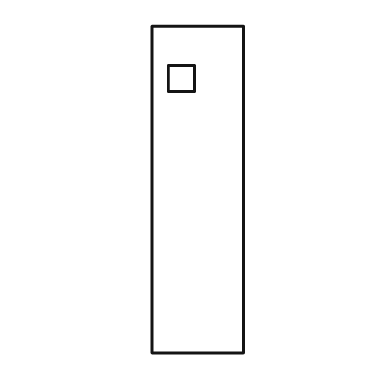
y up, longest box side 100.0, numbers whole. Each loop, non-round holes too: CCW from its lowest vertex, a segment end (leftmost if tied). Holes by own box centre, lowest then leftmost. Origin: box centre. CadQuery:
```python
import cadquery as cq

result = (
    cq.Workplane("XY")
    .moveTo(-14.0, -50.0)
    .lineTo(14.0, -50.0)
    .lineTo(14.0, 50.0)
    .lineTo(-14.0, 50.0)
    .close()
    .moveTo(-9.0, 30.0)
    .lineTo(-1.0, 30.0)
    .lineTo(-1.0, 38.0)
    .lineTo(-9.0, 38.0)
    .close()
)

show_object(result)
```